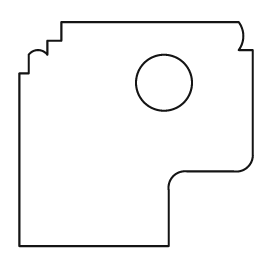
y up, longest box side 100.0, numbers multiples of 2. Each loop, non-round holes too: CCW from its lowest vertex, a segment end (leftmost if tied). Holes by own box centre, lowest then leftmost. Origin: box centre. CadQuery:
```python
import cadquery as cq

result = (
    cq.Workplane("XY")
    .moveTo(-50.0, -48.0)
    .lineTo(14.0, -48.0)
    .lineTo(14.0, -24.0)
    .threePointArc((16.0, -18.0), (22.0, -16.0))
    .lineTo(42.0, -16.0)
    .threePointArc((48.0, -14.0), (50.0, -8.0))
    .lineTo(50.0, 36.0)
    .lineTo(44.0, 36.0)
    .threePointArc((46.0, 42.0), (44.0, 48.0))
    .lineTo(-32.0, 48.0)
    .lineTo(-32.0, 40.0)
    .lineTo(-38.0, 40.0)
    .lineTo(-38.0, 34.0)
    .threePointArc((-42.0, 36.0), (-46.0, 34.0))
    .lineTo(-46.0, 26.0)
    .lineTo(-50.0, 26.0)
    .close()
    .moveTo(12.0, 22.0)
    .circle(12.0)
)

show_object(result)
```